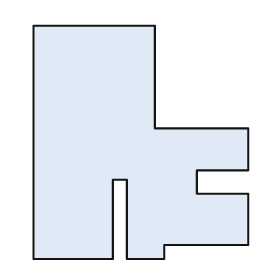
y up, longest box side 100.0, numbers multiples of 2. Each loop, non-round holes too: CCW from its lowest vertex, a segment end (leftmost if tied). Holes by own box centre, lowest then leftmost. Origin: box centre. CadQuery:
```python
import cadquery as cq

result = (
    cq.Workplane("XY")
    .moveTo(-46.0, -50.0)
    .lineTo(-12.0, -50.0)
    .lineTo(-12.0, -16.0)
    .lineTo(-6.0, -16.0)
    .lineTo(-6.0, -50.0)
    .lineTo(10.0, -50.0)
    .lineTo(10.0, -44.0)
    .lineTo(46.0, -44.0)
    .lineTo(46.0, -22.0)
    .lineTo(24.0, -22.0)
    .lineTo(24.0, -12.0)
    .lineTo(46.0, -12.0)
    .lineTo(46.0, 6.0)
    .lineTo(6.0, 6.0)
    .lineTo(6.0, 50.0)
    .lineTo(-46.0, 50.0)
    .close()
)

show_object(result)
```